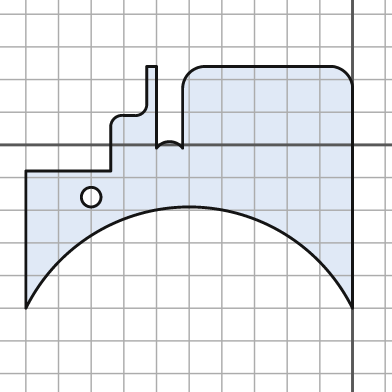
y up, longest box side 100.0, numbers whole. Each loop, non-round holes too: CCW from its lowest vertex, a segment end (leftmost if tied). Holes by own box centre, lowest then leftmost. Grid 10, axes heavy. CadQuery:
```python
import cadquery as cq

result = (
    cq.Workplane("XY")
    .moveTo(-100.0, -50.0)
    .threePointArc((-50.0, -19.0), (0.0, -50.0))
    .lineTo(0.0, 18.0)
    .threePointArc((-2.0, 22.0), (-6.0, 24.0))
    .lineTo(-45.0, 24.0)
    .threePointArc((-50.0, 22.0), (-52.0, 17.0))
    .lineTo(-52.0, -1.0)
    .threePointArc((-56.0, 1.0), (-60.0, -1.0))
    .lineTo(-60.0, 24.0)
    .lineTo(-63.0, 24.0)
    .lineTo(-63.0, 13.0)
    .threePointArc((-64.0, 10.0), (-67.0, 9.0))
    .lineTo(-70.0, 9.0)
    .threePointArc((-73.0, 8.0), (-74.0, 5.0))
    .lineTo(-74.0, -8.0)
    .lineTo(-100.0, -8.0)
    .close()
    .moveTo(-80.0, -16.0)
    .circle(3.0)
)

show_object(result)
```